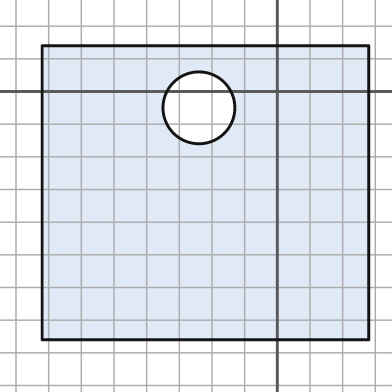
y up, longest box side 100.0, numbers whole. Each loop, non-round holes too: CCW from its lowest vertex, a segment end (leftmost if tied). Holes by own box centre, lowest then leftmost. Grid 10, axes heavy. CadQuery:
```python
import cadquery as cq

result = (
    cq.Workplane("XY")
    .moveTo(-72.0, -76.0)
    .lineTo(28.0, -76.0)
    .lineTo(28.0, 14.0)
    .lineTo(-72.0, 14.0)
    .close()
    .moveTo(-24.0, -5.0)
    .circle(11.0)
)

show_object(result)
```